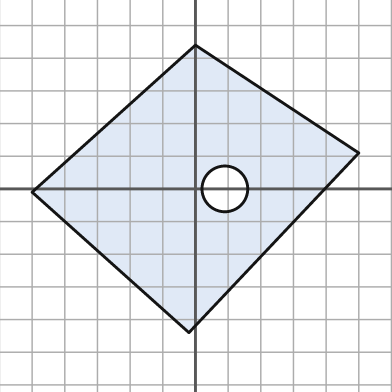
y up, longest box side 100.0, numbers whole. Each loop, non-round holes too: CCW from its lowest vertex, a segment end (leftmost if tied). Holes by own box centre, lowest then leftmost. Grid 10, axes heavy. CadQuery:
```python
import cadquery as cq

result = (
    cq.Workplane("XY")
    .moveTo(-2.0, -44.0)
    .lineTo(50.0, 11.0)
    .lineTo(0.0, 44.0)
    .lineTo(-50.0, -1.0)
    .close()
    .moveTo(9.0, 0.0)
    .circle(7.0)
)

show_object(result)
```